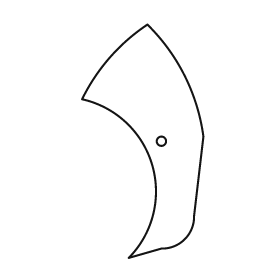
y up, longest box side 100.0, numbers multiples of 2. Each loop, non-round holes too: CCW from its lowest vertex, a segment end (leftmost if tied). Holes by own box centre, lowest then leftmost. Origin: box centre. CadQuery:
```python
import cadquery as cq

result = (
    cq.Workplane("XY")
    .moveTo(-6.0, -50.0)
    .lineTo(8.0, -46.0)
    .threePointArc((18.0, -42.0), (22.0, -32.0))
    .lineTo(26.0, 2.0)
    .threePointArc((18.0, 28.0), (2.0, 50.0))
    .threePointArc((-14.0, 36.0), (-26.0, 18.0))
    .threePointArc((4.0, -10.0), (-6.0, -50.0))
    .close()
    .moveTo(8.0, 0.0)
    .circle(2.0)
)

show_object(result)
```